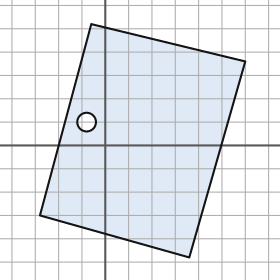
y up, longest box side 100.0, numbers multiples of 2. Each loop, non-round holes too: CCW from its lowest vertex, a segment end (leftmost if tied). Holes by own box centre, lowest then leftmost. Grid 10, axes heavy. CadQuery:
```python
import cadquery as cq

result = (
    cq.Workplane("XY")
    .moveTo(36.0, -48.0)
    .lineTo(60.0, 36.0)
    .lineTo(-6.0, 52.0)
    .lineTo(-28.0, -30.0)
    .close()
    .moveTo(-8.0, 10.0)
    .circle(4.0)
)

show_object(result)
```